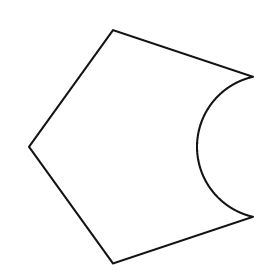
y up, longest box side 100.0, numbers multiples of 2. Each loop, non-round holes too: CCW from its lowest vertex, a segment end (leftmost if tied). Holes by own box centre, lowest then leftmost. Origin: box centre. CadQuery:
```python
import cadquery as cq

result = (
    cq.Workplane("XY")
    .moveTo(-12.0, -50.0)
    .lineTo(48.0, -30.0)
    .threePointArc((24.0, 0.0), (48.0, 30.0))
    .lineTo(-12.0, 50.0)
    .lineTo(-48.0, 0.0)
    .close()
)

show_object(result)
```